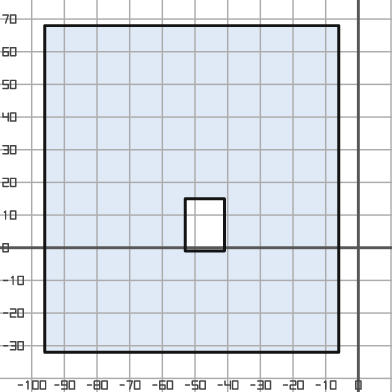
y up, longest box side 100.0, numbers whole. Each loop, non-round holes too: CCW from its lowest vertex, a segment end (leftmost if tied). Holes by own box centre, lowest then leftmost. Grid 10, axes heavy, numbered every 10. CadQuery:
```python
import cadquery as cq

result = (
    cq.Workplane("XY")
    .moveTo(-96.0, -32.0)
    .lineTo(-6.0, -32.0)
    .lineTo(-6.0, 68.0)
    .lineTo(-96.0, 68.0)
    .close()
    .moveTo(-53.0, -1.0)
    .lineTo(-41.0, -1.0)
    .lineTo(-41.0, 15.0)
    .lineTo(-53.0, 15.0)
    .close()
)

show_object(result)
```